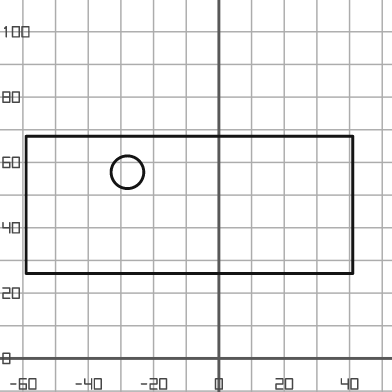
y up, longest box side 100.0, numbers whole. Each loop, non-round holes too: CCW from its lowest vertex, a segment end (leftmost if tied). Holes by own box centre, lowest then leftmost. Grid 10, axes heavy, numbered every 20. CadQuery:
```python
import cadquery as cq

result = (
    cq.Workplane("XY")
    .moveTo(-59.0, 26.0)
    .lineTo(41.0, 26.0)
    .lineTo(41.0, 68.0)
    .lineTo(-59.0, 68.0)
    .close()
    .moveTo(-28.0, 57.0)
    .circle(5.0)
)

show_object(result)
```